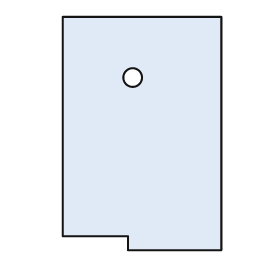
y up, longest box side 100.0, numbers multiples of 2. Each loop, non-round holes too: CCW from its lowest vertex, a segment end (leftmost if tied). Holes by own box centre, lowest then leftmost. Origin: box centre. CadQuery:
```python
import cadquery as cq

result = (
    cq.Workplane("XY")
    .moveTo(-6.0, -50.0)
    .lineTo(34.0, -50.0)
    .lineTo(34.0, 50.0)
    .lineTo(-34.0, 50.0)
    .lineTo(-34.0, -44.0)
    .lineTo(-6.0, -44.0)
    .close()
    .moveTo(-4.0, 24.0)
    .circle(4.0)
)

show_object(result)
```